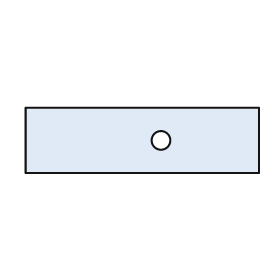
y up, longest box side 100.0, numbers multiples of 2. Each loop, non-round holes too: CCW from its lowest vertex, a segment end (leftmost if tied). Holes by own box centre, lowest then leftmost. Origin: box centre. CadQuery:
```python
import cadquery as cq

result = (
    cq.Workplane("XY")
    .moveTo(-50.0, -14.0)
    .lineTo(50.0, -14.0)
    .lineTo(50.0, 14.0)
    .lineTo(-50.0, 14.0)
    .close()
    .moveTo(8.0, 0.0)
    .circle(4.0)
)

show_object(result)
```